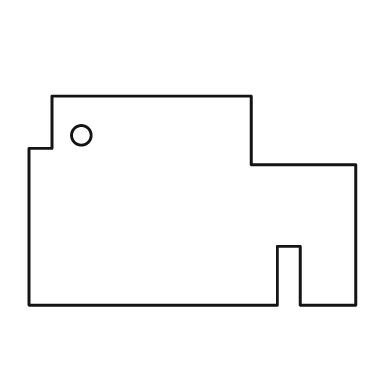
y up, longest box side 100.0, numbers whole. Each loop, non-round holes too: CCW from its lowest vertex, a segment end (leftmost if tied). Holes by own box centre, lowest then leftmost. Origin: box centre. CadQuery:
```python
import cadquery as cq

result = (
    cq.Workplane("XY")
    .moveTo(-50.0, -32.0)
    .lineTo(26.0, -32.0)
    .lineTo(26.0, -14.0)
    .lineTo(33.0, -14.0)
    .lineTo(33.0, -32.0)
    .lineTo(50.0, -32.0)
    .lineTo(50.0, 11.0)
    .lineTo(18.0, 11.0)
    .lineTo(18.0, 32.0)
    .lineTo(-43.0, 32.0)
    .lineTo(-43.0, 16.0)
    .lineTo(-50.0, 16.0)
    .close()
    .moveTo(-34.0, 20.0)
    .circle(3.0)
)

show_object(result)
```